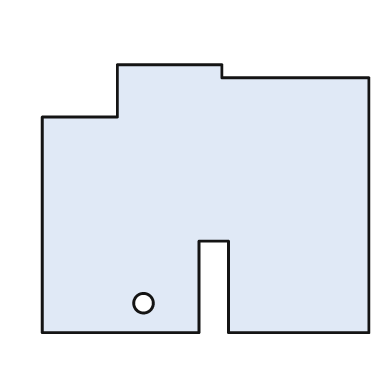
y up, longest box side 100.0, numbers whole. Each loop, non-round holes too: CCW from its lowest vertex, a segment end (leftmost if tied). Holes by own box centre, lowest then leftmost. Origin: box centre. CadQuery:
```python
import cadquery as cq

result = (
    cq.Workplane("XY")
    .moveTo(-50.0, -41.0)
    .lineTo(-2.0, -41.0)
    .lineTo(-2.0, -13.0)
    .lineTo(7.0, -13.0)
    .lineTo(7.0, -41.0)
    .lineTo(50.0, -41.0)
    .lineTo(50.0, 37.0)
    .lineTo(5.0, 37.0)
    .lineTo(5.0, 41.0)
    .lineTo(-27.0, 41.0)
    .lineTo(-27.0, 25.0)
    .lineTo(-50.0, 25.0)
    .close()
    .moveTo(-19.0, -32.0)
    .circle(3.0)
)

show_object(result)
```